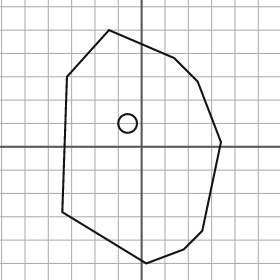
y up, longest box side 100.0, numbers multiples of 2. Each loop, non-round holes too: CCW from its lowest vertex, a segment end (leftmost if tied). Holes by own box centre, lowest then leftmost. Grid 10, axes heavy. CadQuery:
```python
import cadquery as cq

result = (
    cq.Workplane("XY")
    .moveTo(2.0, -50.0)
    .lineTo(18.0, -44.0)
    .lineTo(26.0, -36.0)
    .lineTo(34.0, 2.0)
    .lineTo(24.0, 28.0)
    .lineTo(14.0, 38.0)
    .lineTo(-14.0, 50.0)
    .lineTo(-32.0, 30.0)
    .lineTo(-34.0, -28.0)
    .close()
    .moveTo(-6.0, 10.0)
    .circle(4.0)
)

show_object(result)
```